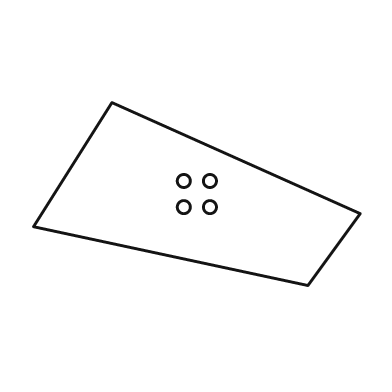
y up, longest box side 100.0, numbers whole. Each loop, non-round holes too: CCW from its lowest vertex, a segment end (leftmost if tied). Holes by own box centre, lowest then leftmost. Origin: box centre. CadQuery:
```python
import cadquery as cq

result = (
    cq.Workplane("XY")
    .moveTo(34.0, -28.0)
    .lineTo(50.0, -6.0)
    .lineTo(-26.0, 28.0)
    .lineTo(-50.0, -10.0)
    .close()
    .moveTo(-4.0, -4.0)
    .circle(2.0)
    .moveTo(4.0, -4.0)
    .circle(2.0)
    .moveTo(-4.0, 4.0)
    .circle(2.0)
    .moveTo(4.0, 4.0)
    .circle(2.0)
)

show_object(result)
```